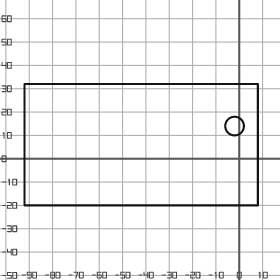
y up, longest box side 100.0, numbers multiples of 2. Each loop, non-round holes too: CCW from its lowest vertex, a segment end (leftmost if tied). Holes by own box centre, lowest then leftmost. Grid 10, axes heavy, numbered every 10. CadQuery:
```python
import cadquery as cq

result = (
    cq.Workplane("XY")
    .moveTo(-92.0, -20.0)
    .lineTo(8.0, -20.0)
    .lineTo(8.0, 32.0)
    .lineTo(-92.0, 32.0)
    .close()
    .moveTo(-2.0, 14.0)
    .circle(4.0)
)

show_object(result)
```